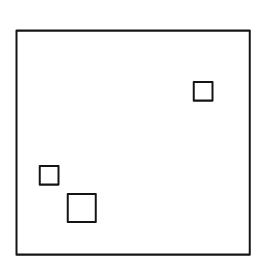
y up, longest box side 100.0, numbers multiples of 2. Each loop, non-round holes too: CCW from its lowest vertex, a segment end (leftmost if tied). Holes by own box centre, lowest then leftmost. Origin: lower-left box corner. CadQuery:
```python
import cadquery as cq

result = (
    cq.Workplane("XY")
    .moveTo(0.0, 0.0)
    .lineTo(100.0, 0.0)
    .lineTo(100.0, 96.0)
    .lineTo(0.0, 96.0)
    .close()
    .moveTo(22.0, 14.0)
    .lineTo(34.0, 14.0)
    .lineTo(34.0, 26.0)
    .lineTo(22.0, 26.0)
    .close()
    .moveTo(10.0, 30.0)
    .lineTo(18.0, 30.0)
    .lineTo(18.0, 38.0)
    .lineTo(10.0, 38.0)
    .close()
    .moveTo(76.0, 66.0)
    .lineTo(84.0, 66.0)
    .lineTo(84.0, 74.0)
    .lineTo(76.0, 74.0)
    .close()
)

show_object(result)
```